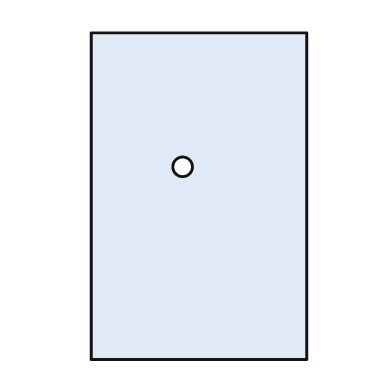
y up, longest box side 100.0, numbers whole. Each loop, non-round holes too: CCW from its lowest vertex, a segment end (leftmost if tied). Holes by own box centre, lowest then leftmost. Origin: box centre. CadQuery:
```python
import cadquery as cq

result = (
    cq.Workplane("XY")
    .moveTo(-33.0, -50.0)
    .lineTo(33.0, -50.0)
    .lineTo(33.0, 50.0)
    .lineTo(-33.0, 50.0)
    .close()
    .moveTo(-5.0, 9.0)
    .circle(3.0)
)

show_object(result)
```